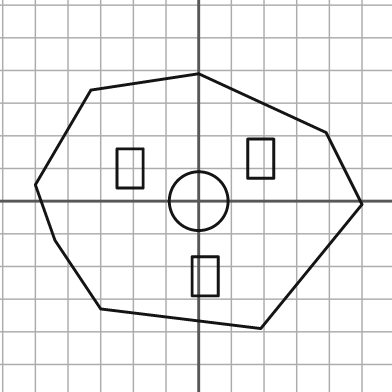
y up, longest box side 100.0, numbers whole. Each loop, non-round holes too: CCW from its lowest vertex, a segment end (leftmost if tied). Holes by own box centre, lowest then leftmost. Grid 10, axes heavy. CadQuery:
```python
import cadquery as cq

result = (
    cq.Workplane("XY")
    .moveTo(19.0, -39.0)
    .lineTo(50.0, -1.0)
    .lineTo(39.0, 21.0)
    .lineTo(0.0, 39.0)
    .lineTo(-33.0, 34.0)
    .lineTo(-50.0, 5.0)
    .lineTo(-44.0, -12.0)
    .lineTo(-30.0, -33.0)
    .close()
    .moveTo(-2.0, -29.0)
    .lineTo(6.0, -29.0)
    .lineTo(6.0, -17.0)
    .lineTo(-2.0, -17.0)
    .close()
    .moveTo(0.0, 0.0)
    .circle(9.0)
    .moveTo(-25.0, 4.0)
    .lineTo(-17.0, 4.0)
    .lineTo(-17.0, 16.0)
    .lineTo(-25.0, 16.0)
    .close()
    .moveTo(15.0, 7.0)
    .lineTo(23.0, 7.0)
    .lineTo(23.0, 19.0)
    .lineTo(15.0, 19.0)
    .close()
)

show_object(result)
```